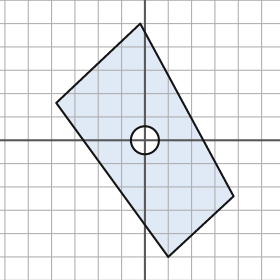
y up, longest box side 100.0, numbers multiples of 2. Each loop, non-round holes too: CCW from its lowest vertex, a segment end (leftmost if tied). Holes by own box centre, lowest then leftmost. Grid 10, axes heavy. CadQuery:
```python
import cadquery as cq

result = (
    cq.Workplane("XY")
    .moveTo(10.0, -50.0)
    .lineTo(38.0, -24.0)
    .lineTo(-2.0, 50.0)
    .lineTo(-38.0, 16.0)
    .close()
    .moveTo(0.0, 0.0)
    .circle(6.0)
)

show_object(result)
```